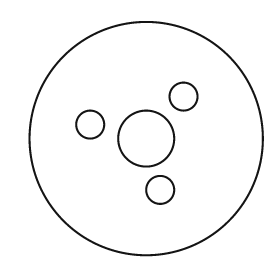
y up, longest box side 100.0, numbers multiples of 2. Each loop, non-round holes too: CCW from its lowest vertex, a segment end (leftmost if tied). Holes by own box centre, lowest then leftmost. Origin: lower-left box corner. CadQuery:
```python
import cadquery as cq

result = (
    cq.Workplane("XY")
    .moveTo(50.0, 50.0)
    .circle(50.0)
    .moveTo(56.0, 28.0)
    .circle(6.0)
    .moveTo(50.0, 50.0)
    .circle(12.0)
    .moveTo(26.0, 56.0)
    .circle(6.0)
    .moveTo(66.0, 68.0)
    .circle(6.0)
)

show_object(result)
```